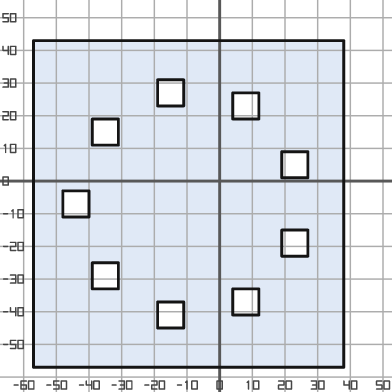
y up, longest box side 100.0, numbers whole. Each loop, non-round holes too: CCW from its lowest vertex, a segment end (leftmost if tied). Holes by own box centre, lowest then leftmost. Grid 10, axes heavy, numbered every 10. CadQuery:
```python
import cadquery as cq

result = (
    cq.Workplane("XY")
    .moveTo(-57.0, -57.0)
    .lineTo(38.0, -57.0)
    .lineTo(38.0, 43.0)
    .lineTo(-57.0, 43.0)
    .close()
    .moveTo(-19.0, -45.0)
    .lineTo(-11.0, -45.0)
    .lineTo(-11.0, -37.0)
    .lineTo(-19.0, -37.0)
    .close()
    .moveTo(4.0, -41.0)
    .lineTo(12.0, -41.0)
    .lineTo(12.0, -33.0)
    .lineTo(4.0, -33.0)
    .close()
    .moveTo(-39.0, -33.0)
    .lineTo(-31.0, -33.0)
    .lineTo(-31.0, -25.0)
    .lineTo(-39.0, -25.0)
    .close()
    .moveTo(19.0, -23.0)
    .lineTo(27.0, -23.0)
    .lineTo(27.0, -15.0)
    .lineTo(19.0, -15.0)
    .close()
    .moveTo(-48.0, -11.0)
    .lineTo(-40.0, -11.0)
    .lineTo(-40.0, -3.0)
    .lineTo(-48.0, -3.0)
    .close()
    .moveTo(19.0, 1.0)
    .lineTo(27.0, 1.0)
    .lineTo(27.0, 9.0)
    .lineTo(19.0, 9.0)
    .close()
    .moveTo(-39.0, 11.0)
    .lineTo(-31.0, 11.0)
    .lineTo(-31.0, 19.0)
    .lineTo(-39.0, 19.0)
    .close()
    .moveTo(4.0, 19.0)
    .lineTo(12.0, 19.0)
    .lineTo(12.0, 27.0)
    .lineTo(4.0, 27.0)
    .close()
    .moveTo(-19.0, 23.0)
    .lineTo(-11.0, 23.0)
    .lineTo(-11.0, 31.0)
    .lineTo(-19.0, 31.0)
    .close()
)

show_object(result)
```